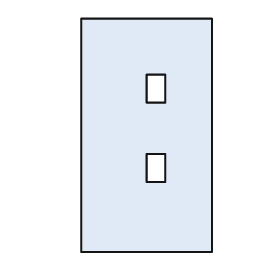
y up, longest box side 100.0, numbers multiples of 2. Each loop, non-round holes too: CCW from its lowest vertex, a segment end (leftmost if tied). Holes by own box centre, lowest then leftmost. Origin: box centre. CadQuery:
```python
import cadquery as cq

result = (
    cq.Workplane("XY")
    .moveTo(-28.0, -50.0)
    .lineTo(28.0, -50.0)
    .lineTo(28.0, 50.0)
    .lineTo(-28.0, 50.0)
    .close()
    .moveTo(0.0, -20.0)
    .lineTo(8.0, -20.0)
    .lineTo(8.0, -8.0)
    .lineTo(0.0, -8.0)
    .close()
    .moveTo(0.0, 14.0)
    .lineTo(8.0, 14.0)
    .lineTo(8.0, 26.0)
    .lineTo(0.0, 26.0)
    .close()
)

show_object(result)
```